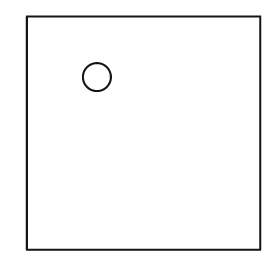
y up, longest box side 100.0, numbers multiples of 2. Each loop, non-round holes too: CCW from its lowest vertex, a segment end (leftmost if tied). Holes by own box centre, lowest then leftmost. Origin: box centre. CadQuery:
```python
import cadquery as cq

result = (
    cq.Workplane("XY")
    .moveTo(-50.0, -50.0)
    .lineTo(50.0, -50.0)
    .lineTo(50.0, 50.0)
    .lineTo(-50.0, 50.0)
    .close()
    .moveTo(-20.0, 24.0)
    .circle(6.0)
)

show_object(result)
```